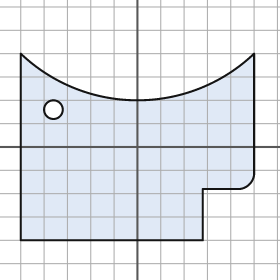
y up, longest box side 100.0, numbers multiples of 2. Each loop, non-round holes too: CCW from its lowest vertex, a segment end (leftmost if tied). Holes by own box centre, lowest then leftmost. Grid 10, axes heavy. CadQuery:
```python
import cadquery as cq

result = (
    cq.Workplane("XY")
    .moveTo(-50.0, -40.0)
    .lineTo(28.0, -40.0)
    .lineTo(28.0, -18.0)
    .lineTo(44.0, -18.0)
    .threePointArc((48.0, -16.0), (50.0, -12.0))
    .lineTo(50.0, 40.0)
    .threePointArc((0.0, 20.0), (-50.0, 40.0))
    .close()
    .moveTo(-36.0, 16.0)
    .circle(4.0)
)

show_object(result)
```